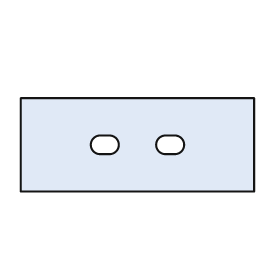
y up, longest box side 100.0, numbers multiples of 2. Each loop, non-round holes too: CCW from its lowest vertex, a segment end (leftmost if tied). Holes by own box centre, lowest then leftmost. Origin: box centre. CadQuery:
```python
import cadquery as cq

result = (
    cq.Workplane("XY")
    .moveTo(-50.0, -20.0)
    .lineTo(50.0, -20.0)
    .lineTo(50.0, 20.0)
    .lineTo(-50.0, 20.0)
    .close()
    .moveTo(-16.0, -4.0)
    .lineTo(-12.0, -4.0)
    .threePointArc((-8.0, 0.0), (-12.0, 4.0))
    .lineTo(-16.0, 4.0)
    .threePointArc((-20.0, 0.0), (-16.0, -4.0))
    .close()
    .moveTo(12.0, -4.0)
    .lineTo(16.0, -4.0)
    .threePointArc((20.0, 0.0), (16.0, 4.0))
    .lineTo(12.0, 4.0)
    .threePointArc((8.0, 0.0), (12.0, -4.0))
    .close()
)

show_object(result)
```